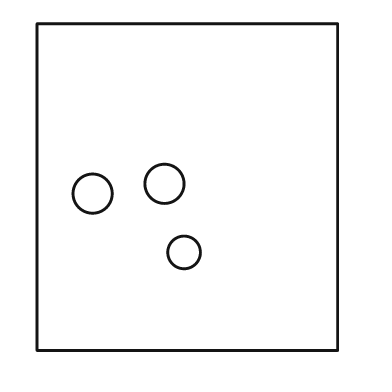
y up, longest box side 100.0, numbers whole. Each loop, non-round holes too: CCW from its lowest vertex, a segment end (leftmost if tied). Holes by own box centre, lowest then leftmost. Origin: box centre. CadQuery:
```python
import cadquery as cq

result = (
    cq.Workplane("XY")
    .moveTo(-46.0, -50.0)
    .lineTo(46.0, -50.0)
    .lineTo(46.0, 50.0)
    .lineTo(-46.0, 50.0)
    .close()
    .moveTo(-1.0, -20.0)
    .circle(5.0)
    .moveTo(-29.0, -2.0)
    .circle(6.0)
    .moveTo(-7.0, 1.0)
    .circle(6.0)
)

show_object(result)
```